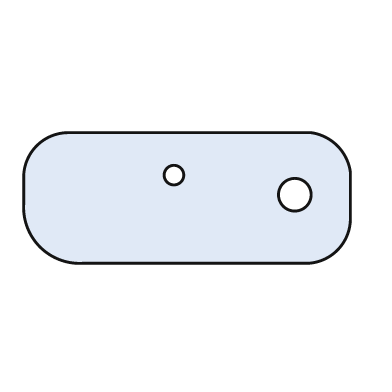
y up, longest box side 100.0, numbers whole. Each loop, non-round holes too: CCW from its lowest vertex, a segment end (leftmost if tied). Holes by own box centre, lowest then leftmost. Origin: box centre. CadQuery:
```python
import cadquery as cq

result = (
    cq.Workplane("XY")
    .moveTo(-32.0, -20.0)
    .lineTo(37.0, -20.0)
    .threePointArc((46.0, -16.0), (50.0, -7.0))
    .lineTo(50.0, 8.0)
    .threePointArc((46.0, 16.0), (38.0, 20.0))
    .lineTo(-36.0, 20.0)
    .threePointArc((-46.0, 16.0), (-50.0, 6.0))
    .lineTo(-50.0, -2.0)
    .threePointArc((-45.0, -15.0), (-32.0, -20.0))
    .close()
    .moveTo(33.0, 1.0)
    .circle(5.0)
    .moveTo(-4.0, 7.0)
    .circle(3.0)
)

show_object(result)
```